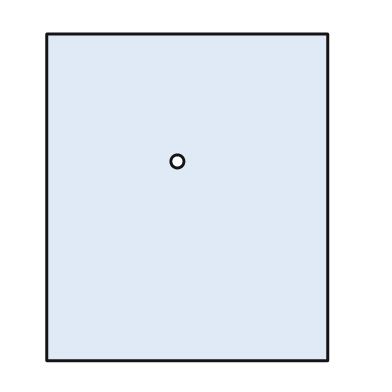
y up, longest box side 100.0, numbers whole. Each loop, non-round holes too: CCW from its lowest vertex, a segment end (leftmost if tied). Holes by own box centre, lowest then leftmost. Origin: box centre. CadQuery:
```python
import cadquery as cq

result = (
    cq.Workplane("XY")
    .moveTo(-43.0, -50.0)
    .lineTo(43.0, -50.0)
    .lineTo(43.0, 50.0)
    .lineTo(-43.0, 50.0)
    .close()
    .moveTo(-3.0, 11.0)
    .circle(2.0)
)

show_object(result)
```